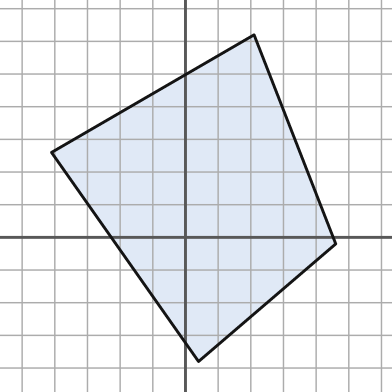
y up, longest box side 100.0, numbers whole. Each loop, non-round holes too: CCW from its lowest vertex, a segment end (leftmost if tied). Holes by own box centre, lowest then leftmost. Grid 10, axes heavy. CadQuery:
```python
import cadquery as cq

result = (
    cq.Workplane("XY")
    .moveTo(4.0, -38.0)
    .lineTo(46.0, -2.0)
    .lineTo(21.0, 62.0)
    .lineTo(-41.0, 26.0)
    .close()
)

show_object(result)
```